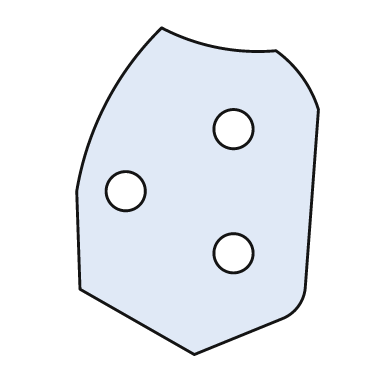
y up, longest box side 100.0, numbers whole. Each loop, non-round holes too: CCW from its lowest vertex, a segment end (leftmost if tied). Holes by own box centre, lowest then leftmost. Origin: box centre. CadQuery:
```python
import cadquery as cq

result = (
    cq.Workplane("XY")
    .moveTo(-1.0, -50.0)
    .lineTo(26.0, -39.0)
    .threePointArc((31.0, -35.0), (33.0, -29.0))
    .lineTo(37.0, 25.0)
    .threePointArc((32.0, 35.0), (24.0, 43.0))
    .threePointArc((6.0, 44.0), (-11.0, 50.0))
    .threePointArc((-28.0, 27.0), (-37.0, 0.0))
    .lineTo(-36.0, -30.0)
    .close()
    .moveTo(11.0, -19.0)
    .circle(6.0)
    .moveTo(-22.0, 0.0)
    .circle(6.0)
    .moveTo(11.0, 19.0)
    .circle(6.0)
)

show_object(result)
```